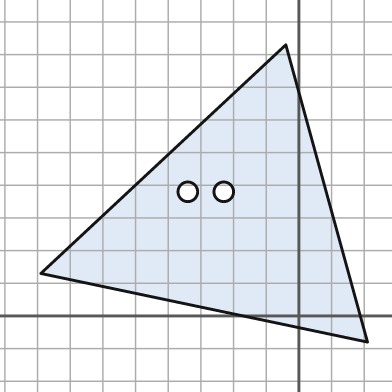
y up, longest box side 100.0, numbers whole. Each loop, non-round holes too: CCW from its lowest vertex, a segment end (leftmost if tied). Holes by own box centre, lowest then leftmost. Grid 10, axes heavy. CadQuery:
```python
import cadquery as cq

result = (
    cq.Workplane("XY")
    .moveTo(21.0, -8.0)
    .lineTo(-4.0, 83.0)
    .lineTo(-79.0, 13.0)
    .close()
    .moveTo(-34.0, 38.0)
    .circle(3.0)
    .moveTo(-23.0, 38.0)
    .circle(3.0)
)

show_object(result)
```